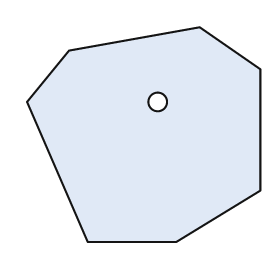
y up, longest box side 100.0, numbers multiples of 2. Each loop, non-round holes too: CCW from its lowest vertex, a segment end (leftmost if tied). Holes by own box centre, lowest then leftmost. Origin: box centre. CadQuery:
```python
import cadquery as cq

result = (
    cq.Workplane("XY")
    .moveTo(-24.0, -46.0)
    .lineTo(14.0, -46.0)
    .lineTo(50.0, -24.0)
    .lineTo(50.0, 28.0)
    .lineTo(24.0, 46.0)
    .lineTo(-32.0, 36.0)
    .lineTo(-50.0, 14.0)
    .close()
    .moveTo(6.0, 14.0)
    .circle(4.0)
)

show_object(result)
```